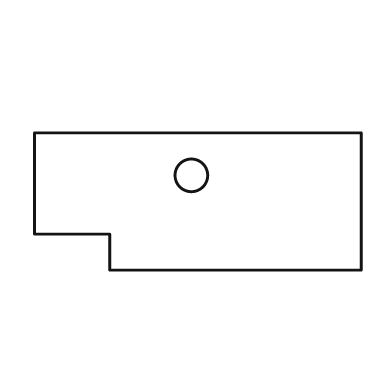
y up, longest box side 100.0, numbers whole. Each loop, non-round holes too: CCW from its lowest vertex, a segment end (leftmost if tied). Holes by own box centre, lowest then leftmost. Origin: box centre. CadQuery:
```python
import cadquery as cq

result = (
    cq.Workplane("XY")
    .moveTo(-27.0, -21.0)
    .lineTo(50.0, -21.0)
    .lineTo(50.0, 21.0)
    .lineTo(-50.0, 21.0)
    .lineTo(-50.0, -10.0)
    .lineTo(-27.0, -10.0)
    .close()
    .moveTo(-2.0, 8.0)
    .circle(5.0)
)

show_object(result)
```